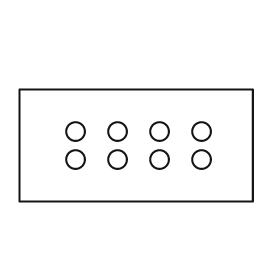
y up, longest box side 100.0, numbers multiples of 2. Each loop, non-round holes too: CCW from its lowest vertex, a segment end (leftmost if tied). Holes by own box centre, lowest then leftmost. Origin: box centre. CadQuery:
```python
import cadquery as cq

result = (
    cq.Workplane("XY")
    .moveTo(-50.0, -24.0)
    .lineTo(50.0, -24.0)
    .lineTo(50.0, 24.0)
    .lineTo(-50.0, 24.0)
    .close()
    .moveTo(-26.0, -6.0)
    .circle(4.0)
    .moveTo(-8.0, -6.0)
    .circle(4.0)
    .moveTo(10.0, -6.0)
    .circle(4.0)
    .moveTo(28.0, -6.0)
    .circle(4.0)
    .moveTo(-26.0, 6.0)
    .circle(4.0)
    .moveTo(-8.0, 6.0)
    .circle(4.0)
    .moveTo(10.0, 6.0)
    .circle(4.0)
    .moveTo(28.0, 6.0)
    .circle(4.0)
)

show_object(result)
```